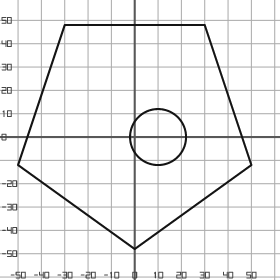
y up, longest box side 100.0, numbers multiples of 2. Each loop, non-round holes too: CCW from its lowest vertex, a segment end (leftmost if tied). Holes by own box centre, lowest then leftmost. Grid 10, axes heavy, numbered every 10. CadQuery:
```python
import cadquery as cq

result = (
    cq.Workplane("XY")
    .moveTo(0.0, -48.0)
    .lineTo(50.0, -12.0)
    .lineTo(30.0, 48.0)
    .lineTo(-30.0, 48.0)
    .lineTo(-50.0, -12.0)
    .close()
    .moveTo(10.0, 0.0)
    .circle(12.0)
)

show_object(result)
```